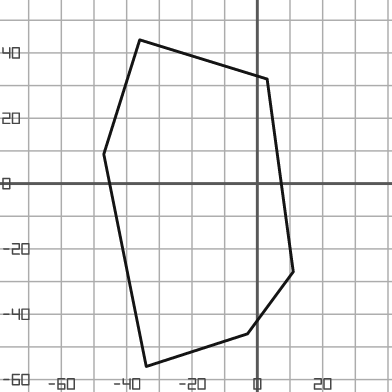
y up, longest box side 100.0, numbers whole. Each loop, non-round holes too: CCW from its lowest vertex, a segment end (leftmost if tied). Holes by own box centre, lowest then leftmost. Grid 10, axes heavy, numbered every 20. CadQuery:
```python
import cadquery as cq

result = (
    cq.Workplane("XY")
    .moveTo(-34.0, -56.0)
    .lineTo(-3.0, -46.0)
    .lineTo(11.0, -27.0)
    .lineTo(3.0, 32.0)
    .lineTo(-36.0, 44.0)
    .lineTo(-47.0, 9.0)
    .close()
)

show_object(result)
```